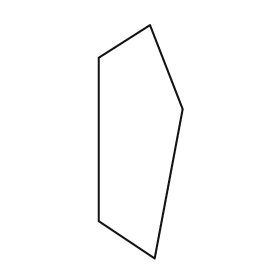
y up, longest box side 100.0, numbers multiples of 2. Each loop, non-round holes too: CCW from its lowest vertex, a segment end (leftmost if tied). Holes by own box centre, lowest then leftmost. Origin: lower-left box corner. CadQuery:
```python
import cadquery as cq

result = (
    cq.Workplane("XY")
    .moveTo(24.0, 0.0)
    .lineTo(36.0, 64.0)
    .lineTo(22.0, 100.0)
    .lineTo(0.0, 86.0)
    .lineTo(0.0, 16.0)
    .close()
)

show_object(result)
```